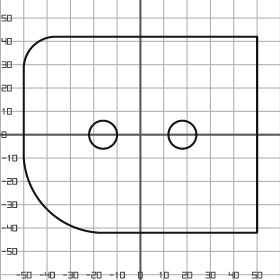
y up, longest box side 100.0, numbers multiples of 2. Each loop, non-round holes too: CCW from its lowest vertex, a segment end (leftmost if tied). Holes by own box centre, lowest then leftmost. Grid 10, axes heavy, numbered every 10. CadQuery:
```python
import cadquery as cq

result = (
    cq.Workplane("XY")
    .moveTo(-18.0, -42.0)
    .lineTo(50.0, -42.0)
    .lineTo(50.0, 42.0)
    .lineTo(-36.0, 42.0)
    .threePointArc((-46.0, 38.0), (-50.0, 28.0))
    .lineTo(-50.0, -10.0)
    .threePointArc((-40.0, -32.0), (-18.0, -42.0))
    .close()
    .moveTo(-16.0, 0.0)
    .circle(6.0)
    .moveTo(18.0, 0.0)
    .circle(6.0)
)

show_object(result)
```